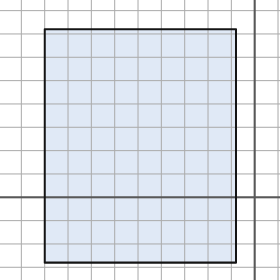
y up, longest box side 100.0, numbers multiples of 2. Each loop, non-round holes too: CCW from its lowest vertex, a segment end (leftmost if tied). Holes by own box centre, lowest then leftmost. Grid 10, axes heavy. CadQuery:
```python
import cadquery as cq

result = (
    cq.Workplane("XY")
    .moveTo(-90.0, -28.0)
    .lineTo(-8.0, -28.0)
    .lineTo(-8.0, 72.0)
    .lineTo(-90.0, 72.0)
    .close()
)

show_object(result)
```